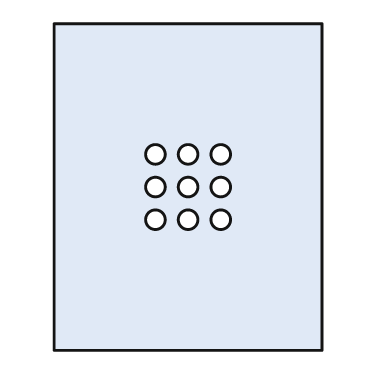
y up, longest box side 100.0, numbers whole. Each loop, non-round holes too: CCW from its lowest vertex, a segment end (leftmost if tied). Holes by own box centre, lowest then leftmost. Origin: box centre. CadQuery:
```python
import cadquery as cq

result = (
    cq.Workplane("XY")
    .moveTo(-41.0, -50.0)
    .lineTo(41.0, -50.0)
    .lineTo(41.0, 50.0)
    .lineTo(-41.0, 50.0)
    .close()
    .moveTo(-10.0, -10.0)
    .circle(3.0)
    .moveTo(0.0, -10.0)
    .circle(3.0)
    .moveTo(10.0, -10.0)
    .circle(3.0)
    .moveTo(-10.0, 0.0)
    .circle(3.0)
    .moveTo(0.0, 0.0)
    .circle(3.0)
    .moveTo(10.0, 0.0)
    .circle(3.0)
    .moveTo(-10.0, 10.0)
    .circle(3.0)
    .moveTo(0.0, 10.0)
    .circle(3.0)
    .moveTo(10.0, 10.0)
    .circle(3.0)
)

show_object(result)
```